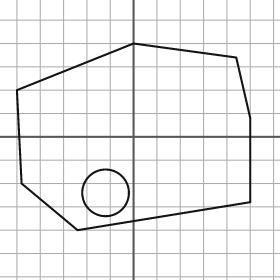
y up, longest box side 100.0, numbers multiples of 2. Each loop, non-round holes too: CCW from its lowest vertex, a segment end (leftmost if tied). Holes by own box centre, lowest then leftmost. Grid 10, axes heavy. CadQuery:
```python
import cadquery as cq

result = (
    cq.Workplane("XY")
    .moveTo(-24.0, -40.0)
    .lineTo(50.0, -28.0)
    .lineTo(50.0, 8.0)
    .lineTo(44.0, 34.0)
    .lineTo(0.0, 40.0)
    .lineTo(-50.0, 20.0)
    .lineTo(-48.0, -20.0)
    .close()
    .moveTo(-12.0, -24.0)
    .circle(10.0)
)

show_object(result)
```